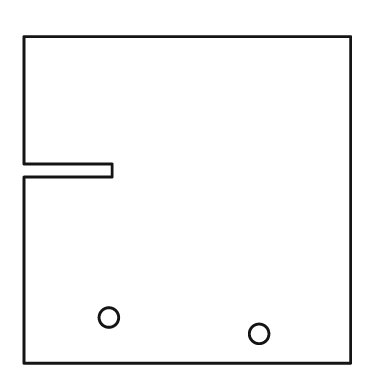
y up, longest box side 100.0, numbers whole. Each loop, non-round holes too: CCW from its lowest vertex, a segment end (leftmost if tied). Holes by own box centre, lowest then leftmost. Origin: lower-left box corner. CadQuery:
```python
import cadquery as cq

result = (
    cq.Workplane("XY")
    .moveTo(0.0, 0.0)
    .lineTo(100.0, 0.0)
    .lineTo(100.0, 100.0)
    .lineTo(0.0, 100.0)
    .lineTo(0.0, 61.0)
    .lineTo(27.0, 61.0)
    .lineTo(27.0, 57.0)
    .lineTo(0.0, 57.0)
    .close()
    .moveTo(72.0, 9.0)
    .circle(3.0)
    .moveTo(26.0, 14.0)
    .circle(3.0)
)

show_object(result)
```